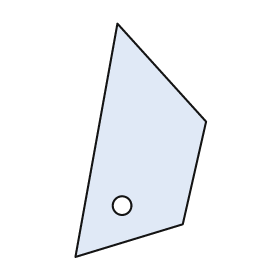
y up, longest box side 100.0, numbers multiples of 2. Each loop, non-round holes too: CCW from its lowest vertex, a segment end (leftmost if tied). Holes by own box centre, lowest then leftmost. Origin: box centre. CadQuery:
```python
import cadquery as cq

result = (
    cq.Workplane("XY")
    .moveTo(-28.0, -50.0)
    .lineTo(18.0, -36.0)
    .lineTo(28.0, 8.0)
    .lineTo(-10.0, 50.0)
    .close()
    .moveTo(-8.0, -28.0)
    .circle(4.0)
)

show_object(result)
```